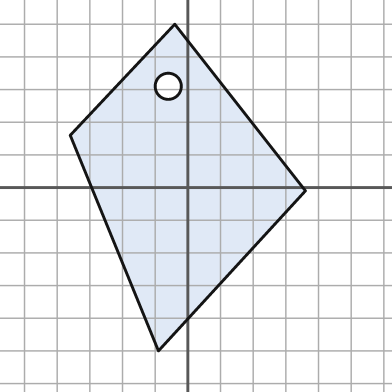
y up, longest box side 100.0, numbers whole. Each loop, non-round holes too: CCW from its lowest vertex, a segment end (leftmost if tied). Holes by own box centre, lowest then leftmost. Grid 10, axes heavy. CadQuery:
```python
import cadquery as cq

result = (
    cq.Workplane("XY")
    .moveTo(-9.0, -50.0)
    .lineTo(36.0, -1.0)
    .lineTo(-4.0, 50.0)
    .lineTo(-36.0, 16.0)
    .close()
    .moveTo(-6.0, 31.0)
    .circle(4.0)
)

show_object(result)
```